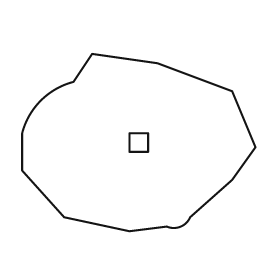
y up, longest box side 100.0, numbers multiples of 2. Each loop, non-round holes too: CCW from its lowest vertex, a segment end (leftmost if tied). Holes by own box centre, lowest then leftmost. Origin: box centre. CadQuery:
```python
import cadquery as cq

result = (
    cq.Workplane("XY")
    .moveTo(-4.0, -38.0)
    .lineTo(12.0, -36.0)
    .threePointArc((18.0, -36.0), (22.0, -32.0))
    .lineTo(40.0, -16.0)
    .lineTo(50.0, -2.0)
    .lineTo(40.0, 22.0)
    .lineTo(8.0, 34.0)
    .lineTo(-20.0, 38.0)
    .lineTo(-28.0, 26.0)
    .threePointArc((-42.0, 18.0), (-50.0, 4.0))
    .lineTo(-50.0, -12.0)
    .lineTo(-32.0, -32.0)
    .close()
    .moveTo(-4.0, -4.0)
    .lineTo(4.0, -4.0)
    .lineTo(4.0, 4.0)
    .lineTo(-4.0, 4.0)
    .close()
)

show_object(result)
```